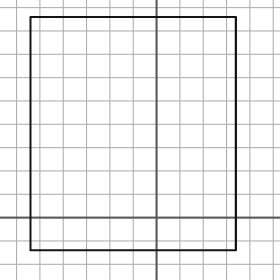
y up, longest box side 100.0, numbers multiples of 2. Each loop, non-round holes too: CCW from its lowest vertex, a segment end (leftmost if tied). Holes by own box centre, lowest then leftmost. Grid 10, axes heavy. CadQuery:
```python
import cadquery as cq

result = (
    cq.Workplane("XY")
    .moveTo(-54.0, -14.0)
    .lineTo(34.0, -14.0)
    .lineTo(34.0, 86.0)
    .lineTo(-54.0, 86.0)
    .close()
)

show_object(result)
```